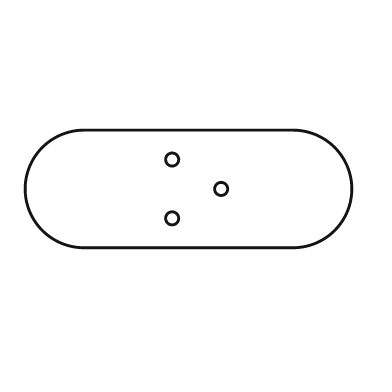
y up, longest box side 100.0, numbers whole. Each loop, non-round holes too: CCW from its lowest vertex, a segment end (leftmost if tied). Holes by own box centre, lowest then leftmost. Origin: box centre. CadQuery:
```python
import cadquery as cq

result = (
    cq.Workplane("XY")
    .moveTo(-32.0, -18.0)
    .lineTo(32.0, -18.0)
    .threePointArc((50.0, 0.0), (32.0, 18.0))
    .lineTo(-32.0, 18.0)
    .threePointArc((-50.0, 0.0), (-32.0, -18.0))
    .close()
    .moveTo(-5.0, -9.0)
    .circle(2.0)
    .moveTo(10.0, 0.0)
    .circle(2.0)
    .moveTo(-5.0, 9.0)
    .circle(2.0)
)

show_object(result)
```